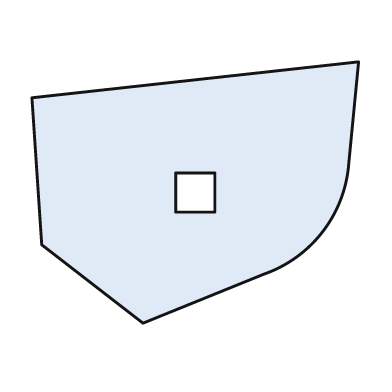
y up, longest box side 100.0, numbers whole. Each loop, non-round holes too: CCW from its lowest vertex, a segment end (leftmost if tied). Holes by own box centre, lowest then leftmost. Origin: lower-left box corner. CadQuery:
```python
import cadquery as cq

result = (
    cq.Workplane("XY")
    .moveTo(34.0, 0.0)
    .lineTo(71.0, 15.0)
    .threePointArc((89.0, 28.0), (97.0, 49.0))
    .lineTo(100.0, 80.0)
    .lineTo(0.0, 69.0)
    .lineTo(3.0, 24.0)
    .close()
    .moveTo(44.0, 34.0)
    .lineTo(56.0, 34.0)
    .lineTo(56.0, 46.0)
    .lineTo(44.0, 46.0)
    .close()
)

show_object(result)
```